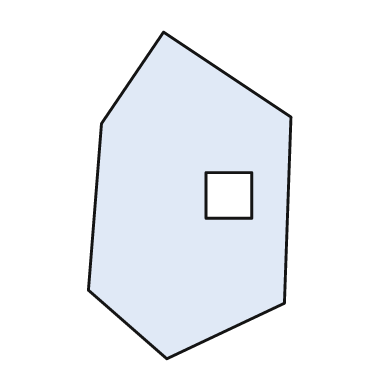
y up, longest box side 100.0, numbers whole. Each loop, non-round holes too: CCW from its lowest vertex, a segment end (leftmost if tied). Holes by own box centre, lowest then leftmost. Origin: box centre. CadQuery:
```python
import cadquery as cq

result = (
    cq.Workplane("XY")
    .moveTo(-7.0, -50.0)
    .lineTo(29.0, -33.0)
    .lineTo(31.0, 24.0)
    .lineTo(-8.0, 50.0)
    .lineTo(-27.0, 22.0)
    .lineTo(-31.0, -29.0)
    .close()
    .moveTo(5.0, -7.0)
    .lineTo(19.0, -7.0)
    .lineTo(19.0, 7.0)
    .lineTo(5.0, 7.0)
    .close()
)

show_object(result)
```